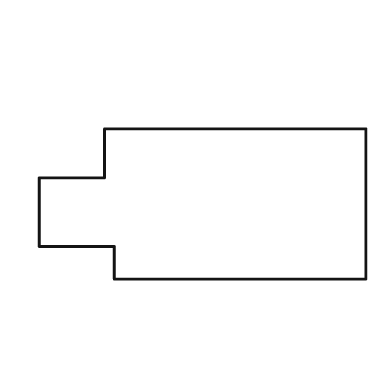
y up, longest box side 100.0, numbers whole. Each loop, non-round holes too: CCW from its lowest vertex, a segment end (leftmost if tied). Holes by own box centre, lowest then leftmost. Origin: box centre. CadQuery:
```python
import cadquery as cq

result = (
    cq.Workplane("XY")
    .moveTo(-27.0, -23.0)
    .lineTo(50.0, -23.0)
    .lineTo(50.0, 23.0)
    .lineTo(-30.0, 23.0)
    .lineTo(-30.0, 8.0)
    .lineTo(-50.0, 8.0)
    .lineTo(-50.0, -13.0)
    .lineTo(-27.0, -13.0)
    .close()
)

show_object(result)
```